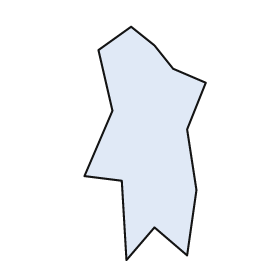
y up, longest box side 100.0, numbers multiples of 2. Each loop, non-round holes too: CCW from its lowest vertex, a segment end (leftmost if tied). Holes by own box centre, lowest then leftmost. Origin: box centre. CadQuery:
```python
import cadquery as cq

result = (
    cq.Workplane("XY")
    .moveTo(-8.0, -50.0)
    .lineTo(4.0, -36.0)
    .lineTo(18.0, -48.0)
    .lineTo(22.0, -20.0)
    .lineTo(18.0, 6.0)
    .lineTo(26.0, 26.0)
    .lineTo(12.0, 32.0)
    .lineTo(4.0, 42.0)
    .lineTo(-6.0, 50.0)
    .lineTo(-20.0, 40.0)
    .lineTo(-14.0, 14.0)
    .lineTo(-26.0, -14.0)
    .lineTo(-10.0, -16.0)
    .close()
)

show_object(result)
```